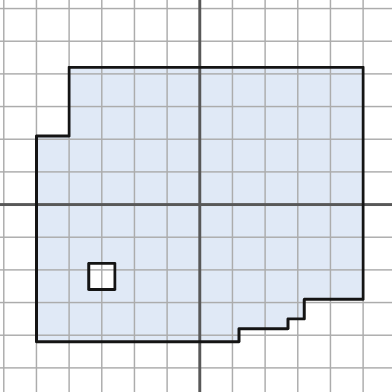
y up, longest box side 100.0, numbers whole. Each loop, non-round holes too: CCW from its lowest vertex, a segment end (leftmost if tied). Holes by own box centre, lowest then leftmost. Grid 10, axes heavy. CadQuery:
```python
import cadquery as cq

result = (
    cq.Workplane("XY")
    .moveTo(-50.0, -42.0)
    .lineTo(12.0, -42.0)
    .lineTo(12.0, -38.0)
    .lineTo(27.0, -38.0)
    .lineTo(27.0, -35.0)
    .lineTo(32.0, -35.0)
    .lineTo(32.0, -29.0)
    .lineTo(50.0, -29.0)
    .lineTo(50.0, 42.0)
    .lineTo(-40.0, 42.0)
    .lineTo(-40.0, 21.0)
    .lineTo(-50.0, 21.0)
    .close()
    .moveTo(-34.0, -26.0)
    .lineTo(-26.0, -26.0)
    .lineTo(-26.0, -18.0)
    .lineTo(-34.0, -18.0)
    .close()
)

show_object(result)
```